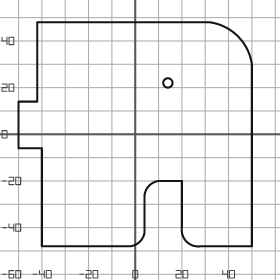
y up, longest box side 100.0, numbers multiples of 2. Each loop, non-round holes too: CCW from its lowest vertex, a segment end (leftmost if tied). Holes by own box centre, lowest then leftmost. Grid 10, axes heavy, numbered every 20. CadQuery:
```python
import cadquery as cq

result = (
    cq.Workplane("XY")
    .moveTo(-40.0, -48.0)
    .lineTo(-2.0, -48.0)
    .threePointArc((2.0, -46.0), (4.0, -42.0))
    .lineTo(4.0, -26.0)
    .threePointArc((6.0, -22.0), (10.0, -20.0))
    .lineTo(20.0, -20.0)
    .lineTo(20.0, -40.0)
    .threePointArc((22.0, -46.0), (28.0, -48.0))
    .lineTo(50.0, -48.0)
    .lineTo(50.0, 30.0)
    .threePointArc((44.0, 42.0), (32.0, 48.0))
    .lineTo(-42.0, 48.0)
    .lineTo(-42.0, 14.0)
    .lineTo(-50.0, 14.0)
    .lineTo(-50.0, -6.0)
    .lineTo(-40.0, -6.0)
    .close()
    .moveTo(14.0, 22.0)
    .circle(2.0)
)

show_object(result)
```